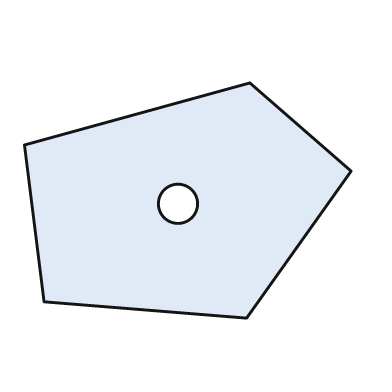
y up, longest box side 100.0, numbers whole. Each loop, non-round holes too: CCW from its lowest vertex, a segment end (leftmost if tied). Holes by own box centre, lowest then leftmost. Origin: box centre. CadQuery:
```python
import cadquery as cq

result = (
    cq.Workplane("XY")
    .moveTo(18.0, -36.0)
    .lineTo(50.0, 9.0)
    .lineTo(19.0, 36.0)
    .lineTo(-50.0, 17.0)
    .lineTo(-44.0, -31.0)
    .close()
    .moveTo(-3.0, -1.0)
    .circle(6.0)
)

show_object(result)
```